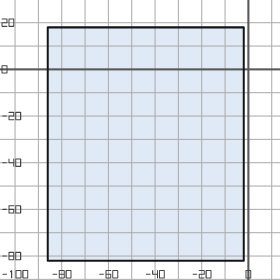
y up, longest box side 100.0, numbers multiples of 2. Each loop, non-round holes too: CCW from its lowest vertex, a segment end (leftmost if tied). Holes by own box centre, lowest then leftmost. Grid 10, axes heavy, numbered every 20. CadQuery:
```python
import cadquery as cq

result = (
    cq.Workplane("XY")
    .moveTo(-86.0, -82.0)
    .lineTo(-2.0, -82.0)
    .lineTo(-2.0, 18.0)
    .lineTo(-86.0, 18.0)
    .close()
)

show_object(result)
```